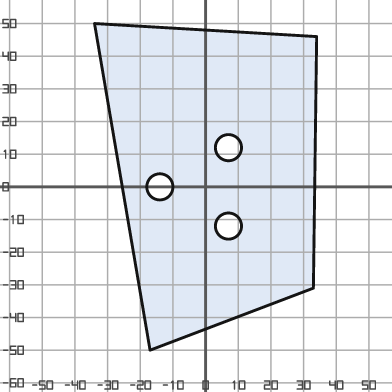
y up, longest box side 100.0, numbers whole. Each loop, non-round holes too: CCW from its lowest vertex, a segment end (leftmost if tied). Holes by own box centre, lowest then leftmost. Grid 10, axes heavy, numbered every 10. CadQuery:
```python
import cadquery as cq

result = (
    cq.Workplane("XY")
    .moveTo(-17.0, -50.0)
    .lineTo(33.0, -31.0)
    .lineTo(34.0, 46.0)
    .lineTo(-34.0, 50.0)
    .close()
    .moveTo(7.0, -12.0)
    .circle(4.0)
    .moveTo(-14.0, 0.0)
    .circle(4.0)
    .moveTo(7.0, 12.0)
    .circle(4.0)
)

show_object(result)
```